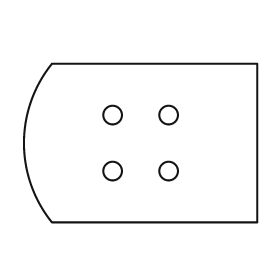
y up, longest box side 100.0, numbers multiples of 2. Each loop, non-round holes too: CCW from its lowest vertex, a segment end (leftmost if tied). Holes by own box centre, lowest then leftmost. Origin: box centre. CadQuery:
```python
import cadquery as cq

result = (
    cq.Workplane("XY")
    .moveTo(-38.0, -34.0)
    .lineTo(50.0, -34.0)
    .lineTo(50.0, 34.0)
    .lineTo(-38.0, 34.0)
    .threePointArc((-50.0, 0.0), (-38.0, -34.0))
    .close()
    .moveTo(-12.0, -12.0)
    .circle(4.0)
    .moveTo(12.0, -12.0)
    .circle(4.0)
    .moveTo(-12.0, 12.0)
    .circle(4.0)
    .moveTo(12.0, 12.0)
    .circle(4.0)
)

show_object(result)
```